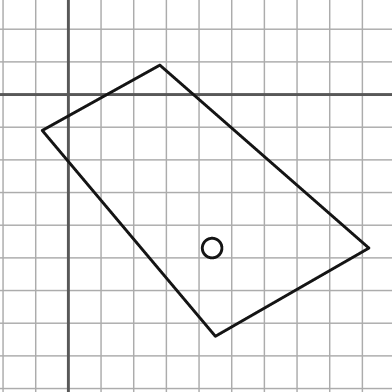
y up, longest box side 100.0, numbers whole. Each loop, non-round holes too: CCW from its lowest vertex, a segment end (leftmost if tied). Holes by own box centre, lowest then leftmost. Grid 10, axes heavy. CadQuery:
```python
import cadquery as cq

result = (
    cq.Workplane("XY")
    .moveTo(45.0, -74.0)
    .lineTo(92.0, -47.0)
    .lineTo(28.0, 9.0)
    .lineTo(-8.0, -11.0)
    .close()
    .moveTo(44.0, -47.0)
    .circle(3.0)
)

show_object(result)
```